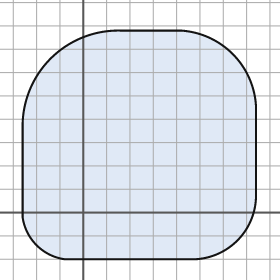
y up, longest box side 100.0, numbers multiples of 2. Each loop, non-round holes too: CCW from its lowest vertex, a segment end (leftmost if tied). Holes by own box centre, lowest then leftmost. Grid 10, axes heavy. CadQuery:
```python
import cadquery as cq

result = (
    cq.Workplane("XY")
    .moveTo(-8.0, -20.0)
    .lineTo(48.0, -20.0)
    .threePointArc((66.0, -12.0), (74.0, 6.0))
    .lineTo(74.0, 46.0)
    .threePointArc((64.0, 68.0), (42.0, 78.0))
    .lineTo(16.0, 78.0)
    .threePointArc((-14.0, 66.0), (-26.0, 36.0))
    .lineTo(-26.0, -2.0)
    .threePointArc((-20.0, -14.0), (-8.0, -20.0))
    .close()
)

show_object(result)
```